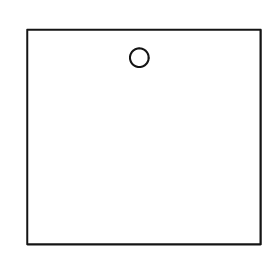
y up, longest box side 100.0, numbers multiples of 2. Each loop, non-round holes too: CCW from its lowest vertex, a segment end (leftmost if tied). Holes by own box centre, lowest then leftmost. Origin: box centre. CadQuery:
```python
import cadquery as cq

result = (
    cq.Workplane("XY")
    .moveTo(-50.0, -46.0)
    .lineTo(50.0, -46.0)
    .lineTo(50.0, 46.0)
    .lineTo(-50.0, 46.0)
    .close()
    .moveTo(-2.0, 34.0)
    .circle(4.0)
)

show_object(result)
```